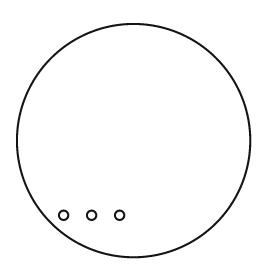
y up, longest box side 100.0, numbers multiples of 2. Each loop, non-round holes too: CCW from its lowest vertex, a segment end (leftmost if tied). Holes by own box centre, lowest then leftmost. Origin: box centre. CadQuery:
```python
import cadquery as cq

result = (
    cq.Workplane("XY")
    .moveTo(0.0, 0.0)
    .circle(50.0)
    .moveTo(-30.0, -32.0)
    .circle(2.0)
    .moveTo(-18.0, -32.0)
    .circle(2.0)
    .moveTo(-6.0, -32.0)
    .circle(2.0)
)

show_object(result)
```